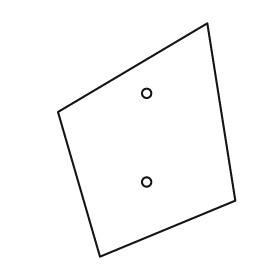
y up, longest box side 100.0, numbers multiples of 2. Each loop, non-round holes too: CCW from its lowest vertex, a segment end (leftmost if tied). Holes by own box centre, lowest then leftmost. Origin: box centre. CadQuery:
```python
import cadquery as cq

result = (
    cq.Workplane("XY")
    .moveTo(-20.0, -50.0)
    .lineTo(38.0, -26.0)
    .lineTo(26.0, 50.0)
    .lineTo(-38.0, 12.0)
    .close()
    .moveTo(0.0, -18.0)
    .circle(2.0)
    .moveTo(0.0, 20.0)
    .circle(2.0)
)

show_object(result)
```